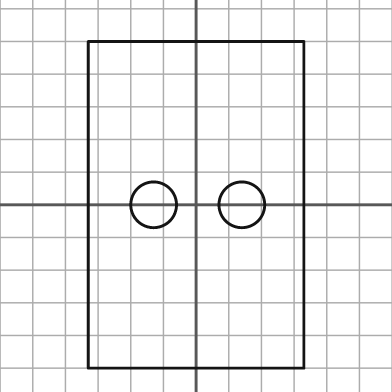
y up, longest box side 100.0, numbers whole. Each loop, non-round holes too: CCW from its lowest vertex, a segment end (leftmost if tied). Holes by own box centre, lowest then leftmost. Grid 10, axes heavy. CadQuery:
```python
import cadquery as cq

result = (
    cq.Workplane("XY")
    .moveTo(-33.0, -50.0)
    .lineTo(33.0, -50.0)
    .lineTo(33.0, 50.0)
    .lineTo(-33.0, 50.0)
    .close()
    .moveTo(-13.0, 0.0)
    .circle(7.0)
    .moveTo(14.0, 0.0)
    .circle(7.0)
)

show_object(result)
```